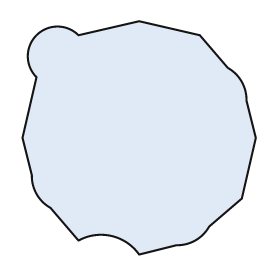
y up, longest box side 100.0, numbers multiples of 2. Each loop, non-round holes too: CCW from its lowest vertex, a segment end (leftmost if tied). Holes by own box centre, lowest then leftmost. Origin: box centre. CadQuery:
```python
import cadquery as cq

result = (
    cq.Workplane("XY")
    .moveTo(0.0, -50.0)
    .lineTo(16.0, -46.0)
    .threePointArc((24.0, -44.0), (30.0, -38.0))
    .lineTo(44.0, -26.0)
    .lineTo(50.0, 0.0)
    .lineTo(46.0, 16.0)
    .threePointArc((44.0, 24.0), (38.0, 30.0))
    .lineTo(26.0, 44.0)
    .lineTo(0.0, 50.0)
    .lineTo(-26.0, 44.0)
    .threePointArc((-44.0, 44.0), (-44.0, 26.0))
    .lineTo(-50.0, 0.0)
    .lineTo(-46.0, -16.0)
    .threePointArc((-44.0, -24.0), (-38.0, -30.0))
    .lineTo(-26.0, -44.0)
    .threePointArc((-12.0, -42.0), (0.0, -50.0))
    .close()
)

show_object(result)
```